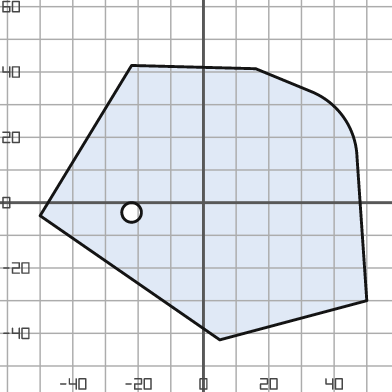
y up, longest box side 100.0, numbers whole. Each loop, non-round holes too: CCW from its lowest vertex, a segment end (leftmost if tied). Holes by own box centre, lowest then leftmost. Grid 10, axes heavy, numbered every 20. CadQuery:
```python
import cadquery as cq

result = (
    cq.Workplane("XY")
    .moveTo(5.0, -42.0)
    .lineTo(50.0, -30.0)
    .lineTo(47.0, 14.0)
    .threePointArc((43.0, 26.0), (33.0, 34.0))
    .lineTo(16.0, 41.0)
    .lineTo(-22.0, 42.0)
    .lineTo(-50.0, -4.0)
    .close()
    .moveTo(-22.0, -3.0)
    .circle(3.0)
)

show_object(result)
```